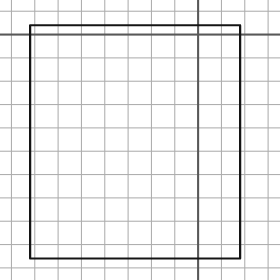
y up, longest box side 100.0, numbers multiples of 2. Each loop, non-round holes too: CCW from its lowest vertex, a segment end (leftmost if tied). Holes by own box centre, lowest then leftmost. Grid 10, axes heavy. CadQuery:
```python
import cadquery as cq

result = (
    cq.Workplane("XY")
    .moveTo(-72.0, -96.0)
    .lineTo(18.0, -96.0)
    .lineTo(18.0, 4.0)
    .lineTo(-72.0, 4.0)
    .close()
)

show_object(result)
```